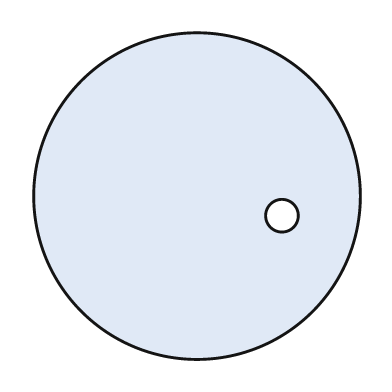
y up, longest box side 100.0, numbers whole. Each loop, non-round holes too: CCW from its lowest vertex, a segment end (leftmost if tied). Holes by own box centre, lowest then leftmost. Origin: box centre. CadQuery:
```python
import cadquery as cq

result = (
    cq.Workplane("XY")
    .moveTo(0.0, 0.0)
    .circle(50.0)
    .moveTo(26.0, -6.0)
    .circle(5.0)
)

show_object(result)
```